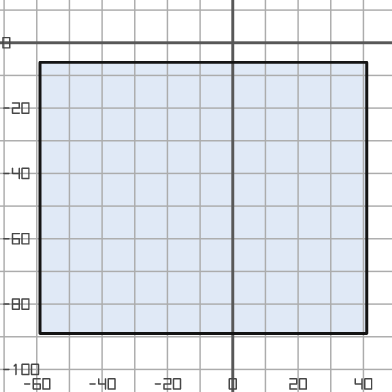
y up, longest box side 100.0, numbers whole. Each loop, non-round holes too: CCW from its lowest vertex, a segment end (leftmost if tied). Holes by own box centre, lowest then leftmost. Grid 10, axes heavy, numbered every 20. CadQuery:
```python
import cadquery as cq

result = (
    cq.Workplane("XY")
    .moveTo(-59.0, -89.0)
    .lineTo(41.0, -89.0)
    .lineTo(41.0, -6.0)
    .lineTo(-59.0, -6.0)
    .close()
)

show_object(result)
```